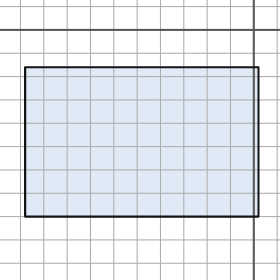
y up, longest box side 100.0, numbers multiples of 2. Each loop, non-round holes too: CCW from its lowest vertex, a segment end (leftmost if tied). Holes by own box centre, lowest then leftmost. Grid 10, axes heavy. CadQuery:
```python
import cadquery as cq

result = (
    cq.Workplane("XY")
    .moveTo(-98.0, -80.0)
    .lineTo(2.0, -80.0)
    .lineTo(2.0, -16.0)
    .lineTo(-98.0, -16.0)
    .close()
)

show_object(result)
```